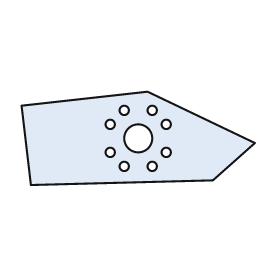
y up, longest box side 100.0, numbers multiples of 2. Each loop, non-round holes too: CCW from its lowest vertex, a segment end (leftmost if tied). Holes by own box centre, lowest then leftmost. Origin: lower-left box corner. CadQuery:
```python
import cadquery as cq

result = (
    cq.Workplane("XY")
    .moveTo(4.0, 0.0)
    .lineTo(82.0, 2.0)
    .lineTo(100.0, 18.0)
    .lineTo(54.0, 40.0)
    .lineTo(0.0, 34.0)
    .close()
    .moveTo(44.0, 8.0)
    .circle(2.0)
    .moveTo(56.0, 8.0)
    .circle(2.0)
    .moveTo(38.0, 14.0)
    .circle(2.0)
    .moveTo(62.0, 14.0)
    .circle(2.0)
    .moveTo(50.0, 20.0)
    .circle(6.0)
    .moveTo(38.0, 26.0)
    .circle(2.0)
    .moveTo(62.0, 26.0)
    .circle(2.0)
    .moveTo(44.0, 32.0)
    .circle(2.0)
    .moveTo(56.0, 32.0)
    .circle(2.0)
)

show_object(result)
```